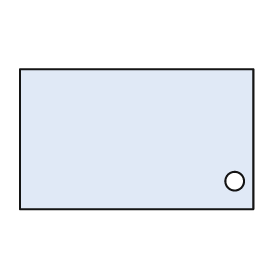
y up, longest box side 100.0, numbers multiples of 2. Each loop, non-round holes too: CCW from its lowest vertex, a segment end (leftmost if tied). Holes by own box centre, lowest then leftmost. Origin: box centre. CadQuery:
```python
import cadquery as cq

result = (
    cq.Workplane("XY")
    .moveTo(-50.0, -30.0)
    .lineTo(50.0, -30.0)
    .lineTo(50.0, 30.0)
    .lineTo(-50.0, 30.0)
    .close()
    .moveTo(42.0, -18.0)
    .circle(4.0)
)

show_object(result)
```